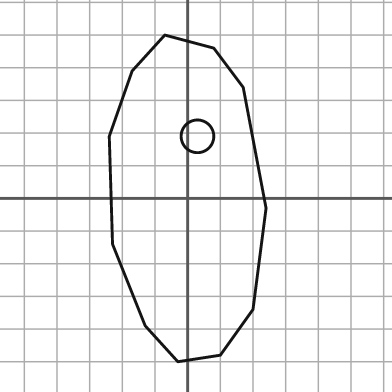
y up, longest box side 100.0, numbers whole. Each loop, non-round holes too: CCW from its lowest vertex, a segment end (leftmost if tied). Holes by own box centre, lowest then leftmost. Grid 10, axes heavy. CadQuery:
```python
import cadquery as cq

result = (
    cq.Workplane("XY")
    .moveTo(-3.0, -50.0)
    .lineTo(10.0, -48.0)
    .lineTo(20.0, -34.0)
    .lineTo(24.0, -3.0)
    .lineTo(17.0, 34.0)
    .lineTo(8.0, 46.0)
    .lineTo(-7.0, 50.0)
    .lineTo(-17.0, 39.0)
    .lineTo(-24.0, 19.0)
    .lineTo(-23.0, -14.0)
    .lineTo(-13.0, -39.0)
    .close()
    .moveTo(3.0, 19.0)
    .circle(5.0)
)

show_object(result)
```